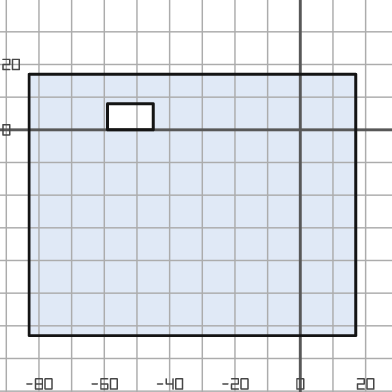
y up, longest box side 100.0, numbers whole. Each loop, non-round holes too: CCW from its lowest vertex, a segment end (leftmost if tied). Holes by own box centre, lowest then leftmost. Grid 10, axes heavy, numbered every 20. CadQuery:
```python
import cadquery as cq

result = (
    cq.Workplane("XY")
    .moveTo(-83.0, -63.0)
    .lineTo(17.0, -63.0)
    .lineTo(17.0, 17.0)
    .lineTo(-83.0, 17.0)
    .close()
    .moveTo(-59.0, 0.0)
    .lineTo(-45.0, 0.0)
    .lineTo(-45.0, 8.0)
    .lineTo(-59.0, 8.0)
    .close()
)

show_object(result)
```